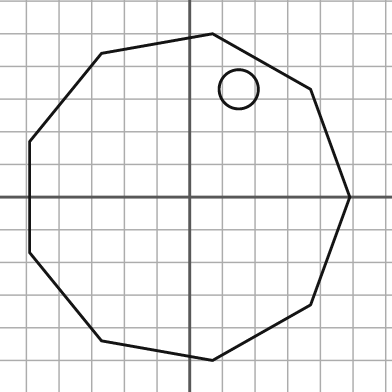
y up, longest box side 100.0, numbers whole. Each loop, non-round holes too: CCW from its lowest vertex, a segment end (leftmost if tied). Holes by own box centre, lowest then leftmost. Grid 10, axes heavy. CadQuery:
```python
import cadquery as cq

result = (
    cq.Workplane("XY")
    .moveTo(7.0, -50.0)
    .lineTo(37.0, -33.0)
    .lineTo(49.0, 0.0)
    .lineTo(37.0, 33.0)
    .lineTo(7.0, 50.0)
    .lineTo(-27.0, 44.0)
    .lineTo(-49.0, 17.0)
    .lineTo(-49.0, -17.0)
    .lineTo(-27.0, -44.0)
    .close()
    .moveTo(15.0, 33.0)
    .circle(6.0)
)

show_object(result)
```